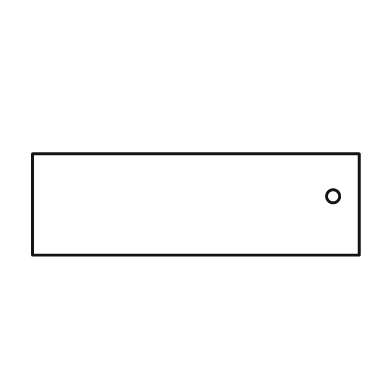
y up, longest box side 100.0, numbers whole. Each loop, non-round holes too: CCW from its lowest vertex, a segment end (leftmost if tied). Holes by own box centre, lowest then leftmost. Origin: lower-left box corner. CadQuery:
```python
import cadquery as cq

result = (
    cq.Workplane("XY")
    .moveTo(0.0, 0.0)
    .lineTo(100.0, 0.0)
    .lineTo(100.0, 31.0)
    .lineTo(0.0, 31.0)
    .close()
    .moveTo(92.0, 18.0)
    .circle(2.0)
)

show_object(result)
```